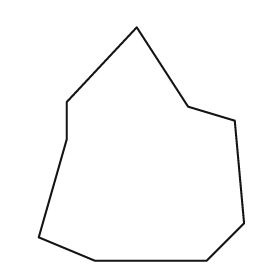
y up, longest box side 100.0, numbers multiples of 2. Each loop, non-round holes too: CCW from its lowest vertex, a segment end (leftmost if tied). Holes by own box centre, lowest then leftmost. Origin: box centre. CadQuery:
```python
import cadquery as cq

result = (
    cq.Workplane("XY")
    .moveTo(-20.0, -50.0)
    .lineTo(28.0, -50.0)
    .lineTo(44.0, -34.0)
    .lineTo(40.0, 10.0)
    .lineTo(20.0, 16.0)
    .lineTo(-2.0, 50.0)
    .lineTo(-32.0, 18.0)
    .lineTo(-32.0, 2.0)
    .lineTo(-44.0, -40.0)
    .close()
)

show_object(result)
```